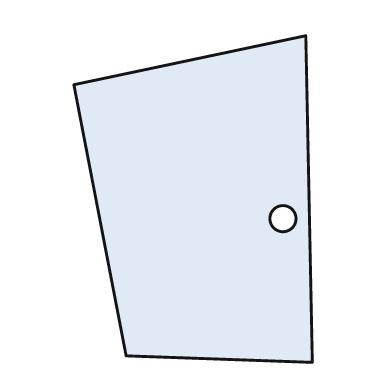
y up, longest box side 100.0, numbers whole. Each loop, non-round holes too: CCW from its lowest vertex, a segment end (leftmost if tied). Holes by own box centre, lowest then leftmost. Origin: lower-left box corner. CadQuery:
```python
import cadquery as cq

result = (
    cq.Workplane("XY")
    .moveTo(73.0, 0.0)
    .lineTo(71.0, 100.0)
    .lineTo(0.0, 85.0)
    .lineTo(16.0, 2.0)
    .close()
    .moveTo(64.0, 44.0)
    .circle(4.0)
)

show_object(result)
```